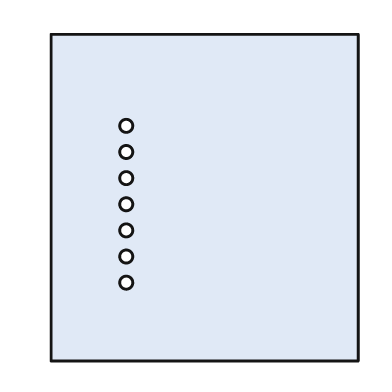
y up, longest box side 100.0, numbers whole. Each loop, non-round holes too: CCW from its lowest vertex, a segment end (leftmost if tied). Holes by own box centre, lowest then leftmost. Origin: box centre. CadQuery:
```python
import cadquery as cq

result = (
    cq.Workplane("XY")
    .moveTo(-47.0, -50.0)
    .lineTo(47.0, -50.0)
    .lineTo(47.0, 50.0)
    .lineTo(-47.0, 50.0)
    .close()
    .moveTo(-24.0, -26.0)
    .circle(2.0)
    .moveTo(-24.0, -18.0)
    .circle(2.0)
    .moveTo(-24.0, -10.0)
    .circle(2.0)
    .moveTo(-24.0, -2.0)
    .circle(2.0)
    .moveTo(-24.0, 6.0)
    .circle(2.0)
    .moveTo(-24.0, 14.0)
    .circle(2.0)
    .moveTo(-24.0, 22.0)
    .circle(2.0)
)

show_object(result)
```